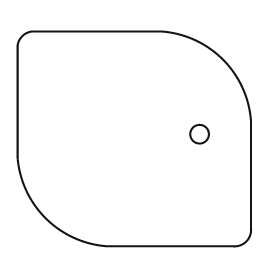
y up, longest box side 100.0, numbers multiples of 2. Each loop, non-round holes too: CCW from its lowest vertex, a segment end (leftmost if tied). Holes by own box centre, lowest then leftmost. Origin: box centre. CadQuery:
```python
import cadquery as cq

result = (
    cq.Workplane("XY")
    .moveTo(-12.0, -46.0)
    .lineTo(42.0, -46.0)
    .threePointArc((48.0, -44.0), (50.0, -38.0))
    .lineTo(50.0, 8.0)
    .threePointArc((38.0, 34.0), (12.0, 46.0))
    .lineTo(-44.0, 46.0)
    .threePointArc((-48.0, 44.0), (-50.0, 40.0))
    .lineTo(-50.0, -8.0)
    .threePointArc((-38.0, -34.0), (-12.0, -46.0))
    .close()
    .moveTo(28.0, 2.0)
    .circle(4.0)
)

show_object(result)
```